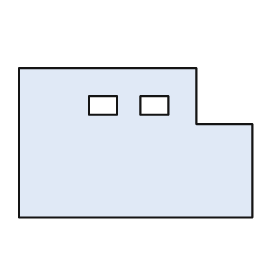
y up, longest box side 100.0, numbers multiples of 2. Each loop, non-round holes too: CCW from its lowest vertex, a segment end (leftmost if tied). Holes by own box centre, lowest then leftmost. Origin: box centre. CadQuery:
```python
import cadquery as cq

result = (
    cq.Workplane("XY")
    .moveTo(-50.0, -32.0)
    .lineTo(50.0, -32.0)
    .lineTo(50.0, 8.0)
    .lineTo(26.0, 8.0)
    .lineTo(26.0, 32.0)
    .lineTo(-50.0, 32.0)
    .close()
    .moveTo(-20.0, 12.0)
    .lineTo(-8.0, 12.0)
    .lineTo(-8.0, 20.0)
    .lineTo(-20.0, 20.0)
    .close()
    .moveTo(2.0, 12.0)
    .lineTo(14.0, 12.0)
    .lineTo(14.0, 20.0)
    .lineTo(2.0, 20.0)
    .close()
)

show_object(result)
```